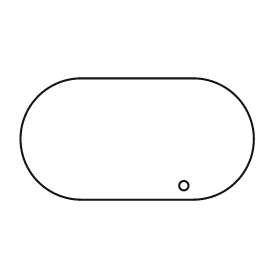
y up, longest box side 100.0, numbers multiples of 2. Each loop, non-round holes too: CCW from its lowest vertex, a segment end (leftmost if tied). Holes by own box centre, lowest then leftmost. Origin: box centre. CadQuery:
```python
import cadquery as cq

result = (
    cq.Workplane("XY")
    .moveTo(-24.0, -26.0)
    .lineTo(24.0, -26.0)
    .threePointArc((50.0, 0.0), (24.0, 26.0))
    .lineTo(-24.0, 26.0)
    .threePointArc((-50.0, 0.0), (-24.0, -26.0))
    .close()
    .moveTo(20.0, -20.0)
    .circle(2.0)
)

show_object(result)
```